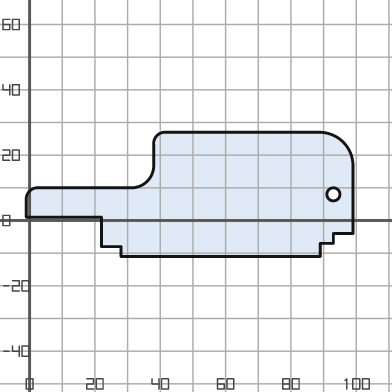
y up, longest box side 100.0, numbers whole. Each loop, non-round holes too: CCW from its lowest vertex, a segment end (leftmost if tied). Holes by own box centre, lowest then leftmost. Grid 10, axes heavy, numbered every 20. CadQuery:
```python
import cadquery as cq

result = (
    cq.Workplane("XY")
    .moveTo(28.0, -11.0)
    .lineTo(89.0, -11.0)
    .lineTo(89.0, -7.0)
    .lineTo(93.0, -7.0)
    .lineTo(93.0, -4.0)
    .lineTo(99.0, -4.0)
    .lineTo(99.0, 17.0)
    .threePointArc((96.0, 24.0), (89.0, 27.0))
    .lineTo(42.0, 27.0)
    .threePointArc((39.0, 26.0), (38.0, 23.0))
    .lineTo(38.0, 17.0)
    .threePointArc((36.0, 12.0), (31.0, 10.0))
    .lineTo(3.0, 10.0)
    .threePointArc((0.0, 9.0), (-1.0, 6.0))
    .lineTo(-1.0, 1.0)
    .lineTo(22.0, 1.0)
    .lineTo(22.0, -8.0)
    .lineTo(28.0, -8.0)
    .close()
    .moveTo(93.0, 8.0)
    .circle(2.0)
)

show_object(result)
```